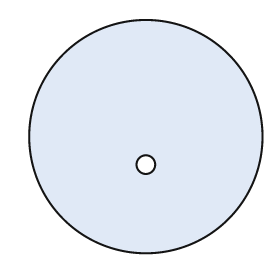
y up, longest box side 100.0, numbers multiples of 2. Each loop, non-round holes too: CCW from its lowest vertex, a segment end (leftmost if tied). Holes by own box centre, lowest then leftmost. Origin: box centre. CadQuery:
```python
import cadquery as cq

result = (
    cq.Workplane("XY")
    .moveTo(0.0, 0.0)
    .circle(50.0)
    .moveTo(0.0, -12.0)
    .circle(4.0)
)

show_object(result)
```